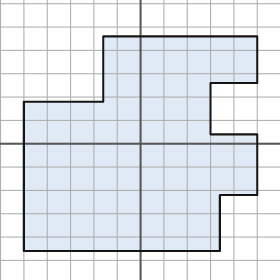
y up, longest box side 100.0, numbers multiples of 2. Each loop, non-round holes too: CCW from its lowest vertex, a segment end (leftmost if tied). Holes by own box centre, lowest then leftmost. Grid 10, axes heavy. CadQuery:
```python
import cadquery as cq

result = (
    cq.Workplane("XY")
    .moveTo(-50.0, -46.0)
    .lineTo(34.0, -46.0)
    .lineTo(34.0, -22.0)
    .lineTo(50.0, -22.0)
    .lineTo(50.0, 4.0)
    .lineTo(30.0, 4.0)
    .lineTo(30.0, 26.0)
    .lineTo(50.0, 26.0)
    .lineTo(50.0, 46.0)
    .lineTo(-16.0, 46.0)
    .lineTo(-16.0, 18.0)
    .lineTo(-50.0, 18.0)
    .close()
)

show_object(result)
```